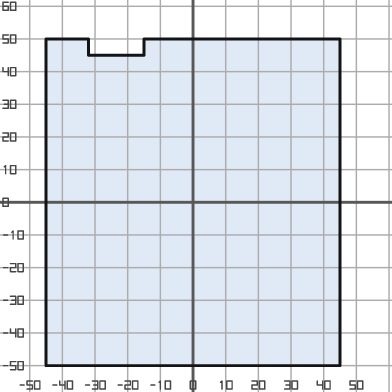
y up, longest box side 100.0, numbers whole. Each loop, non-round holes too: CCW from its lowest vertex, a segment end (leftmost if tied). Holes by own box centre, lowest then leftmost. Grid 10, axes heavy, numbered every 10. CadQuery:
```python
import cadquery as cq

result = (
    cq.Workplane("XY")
    .moveTo(-45.0, -50.0)
    .lineTo(45.0, -50.0)
    .lineTo(45.0, 50.0)
    .lineTo(-15.0, 50.0)
    .lineTo(-15.0, 45.0)
    .lineTo(-32.0, 45.0)
    .lineTo(-32.0, 50.0)
    .lineTo(-45.0, 50.0)
    .close()
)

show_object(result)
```